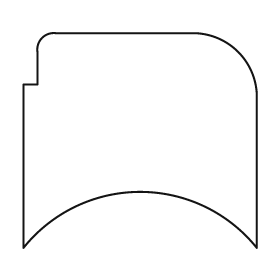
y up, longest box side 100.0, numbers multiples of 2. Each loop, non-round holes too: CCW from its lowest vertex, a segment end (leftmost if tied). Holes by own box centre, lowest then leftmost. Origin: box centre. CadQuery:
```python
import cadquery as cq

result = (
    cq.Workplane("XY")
    .moveTo(-50.0, -46.0)
    .threePointArc((0.0, -22.0), (50.0, -46.0))
    .lineTo(50.0, 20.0)
    .threePointArc((42.0, 38.0), (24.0, 46.0))
    .lineTo(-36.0, 46.0)
    .threePointArc((-42.0, 44.0), (-44.0, 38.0))
    .lineTo(-44.0, 24.0)
    .lineTo(-50.0, 24.0)
    .close()
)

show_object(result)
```